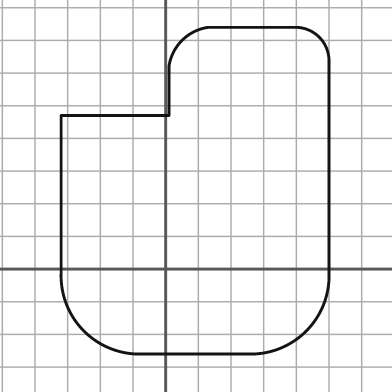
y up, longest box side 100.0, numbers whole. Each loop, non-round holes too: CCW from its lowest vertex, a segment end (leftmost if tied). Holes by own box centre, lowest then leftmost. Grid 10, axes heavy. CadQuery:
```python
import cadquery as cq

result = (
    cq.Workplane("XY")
    .moveTo(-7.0, -26.0)
    .lineTo(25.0, -26.0)
    .threePointArc((43.0, -19.0), (50.0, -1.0))
    .lineTo(50.0, 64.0)
    .threePointArc((47.0, 71.0), (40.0, 74.0))
    .lineTo(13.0, 74.0)
    .threePointArc((5.0, 70.0), (1.0, 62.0))
    .lineTo(1.0, 47.0)
    .lineTo(-32.0, 47.0)
    .lineTo(-32.0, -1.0)
    .threePointArc((-25.0, -19.0), (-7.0, -26.0))
    .close()
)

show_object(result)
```